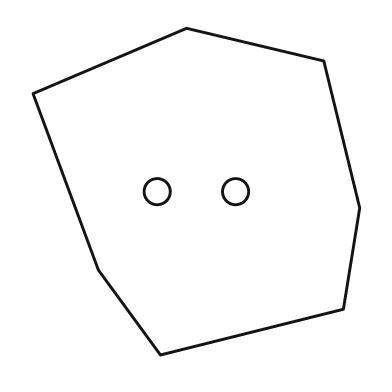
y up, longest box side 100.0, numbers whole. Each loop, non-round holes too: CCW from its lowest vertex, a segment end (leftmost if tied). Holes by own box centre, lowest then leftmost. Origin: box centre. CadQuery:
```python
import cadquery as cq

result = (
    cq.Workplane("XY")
    .moveTo(-11.0, -50.0)
    .lineTo(45.0, -36.0)
    .lineTo(50.0, -5.0)
    .lineTo(39.0, 40.0)
    .lineTo(-3.0, 50.0)
    .lineTo(-50.0, 30.0)
    .lineTo(-30.0, -24.0)
    .close()
    .moveTo(-12.0, 0.0)
    .circle(4.0)
    .moveTo(12.0, 0.0)
    .circle(4.0)
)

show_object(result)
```